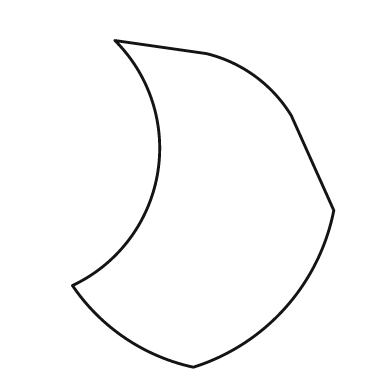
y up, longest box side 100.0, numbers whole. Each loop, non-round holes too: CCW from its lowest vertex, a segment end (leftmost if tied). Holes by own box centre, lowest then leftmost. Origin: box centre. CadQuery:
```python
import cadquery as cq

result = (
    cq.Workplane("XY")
    .moveTo(-3.0, -50.0)
    .threePointArc((25.0, -32.0), (40.0, -2.0))
    .lineTo(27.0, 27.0)
    .threePointArc((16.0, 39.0), (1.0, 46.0))
    .lineTo(-27.0, 50.0)
    .threePointArc((-14.0, 9.0), (-40.0, -25.0))
    .threePointArc((-24.0, -41.0), (-3.0, -50.0))
    .close()
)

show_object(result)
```